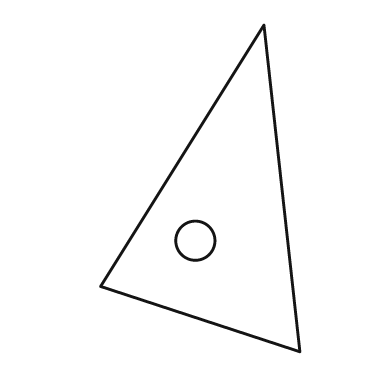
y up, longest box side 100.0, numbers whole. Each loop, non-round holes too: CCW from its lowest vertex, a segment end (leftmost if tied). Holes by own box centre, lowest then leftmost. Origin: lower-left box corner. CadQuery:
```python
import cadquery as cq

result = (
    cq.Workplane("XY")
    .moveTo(61.0, 0.0)
    .lineTo(50.0, 100.0)
    .lineTo(0.0, 20.0)
    .close()
    .moveTo(29.0, 34.0)
    .circle(6.0)
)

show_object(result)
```